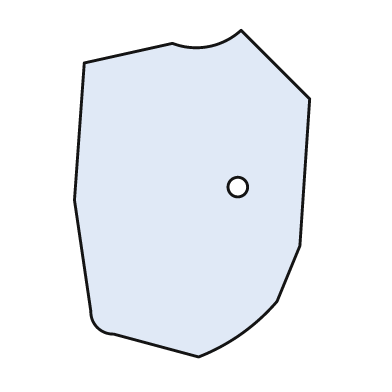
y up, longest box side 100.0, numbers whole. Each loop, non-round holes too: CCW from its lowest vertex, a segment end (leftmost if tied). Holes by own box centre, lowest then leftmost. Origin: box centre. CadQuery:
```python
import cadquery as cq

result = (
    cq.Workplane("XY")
    .moveTo(2.0, -50.0)
    .threePointArc((15.0, -43.0), (26.0, -33.0))
    .lineTo(33.0, -16.0)
    .lineTo(36.0, 29.0)
    .lineTo(15.0, 50.0)
    .threePointArc((5.0, 45.0), (-6.0, 46.0))
    .lineTo(-33.0, 40.0)
    .lineTo(-36.0, -2.0)
    .lineTo(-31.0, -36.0)
    .threePointArc((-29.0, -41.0), (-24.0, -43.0))
    .close()
    .moveTo(14.0, 2.0)
    .circle(3.0)
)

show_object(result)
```